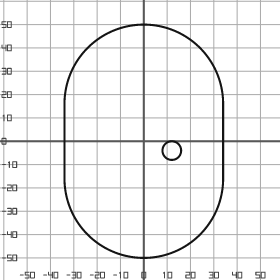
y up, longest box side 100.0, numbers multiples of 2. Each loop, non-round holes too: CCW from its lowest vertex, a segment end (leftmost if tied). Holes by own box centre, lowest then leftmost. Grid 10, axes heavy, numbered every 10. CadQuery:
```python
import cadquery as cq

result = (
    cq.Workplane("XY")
    .moveTo(-34.0, -16.0)
    .threePointArc((0.0, -50.0), (34.0, -16.0))
    .lineTo(34.0, 16.0)
    .threePointArc((0.0, 50.0), (-34.0, 16.0))
    .close()
    .moveTo(12.0, -4.0)
    .circle(4.0)
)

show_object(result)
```